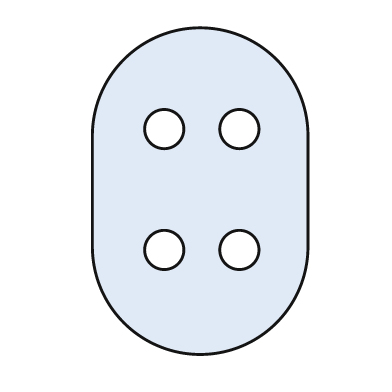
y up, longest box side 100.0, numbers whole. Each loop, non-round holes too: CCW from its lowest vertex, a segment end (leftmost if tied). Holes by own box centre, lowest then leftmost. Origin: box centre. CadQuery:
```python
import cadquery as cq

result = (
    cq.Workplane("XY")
    .moveTo(-33.0, -17.0)
    .threePointArc((0.0, -50.0), (33.0, -17.0))
    .lineTo(33.0, 17.0)
    .threePointArc((0.0, 50.0), (-33.0, 17.0))
    .close()
    .moveTo(-11.0, -18.0)
    .circle(6.0)
    .moveTo(12.0, -18.0)
    .circle(6.0)
    .moveTo(-11.0, 19.0)
    .circle(6.0)
    .moveTo(12.0, 19.0)
    .circle(6.0)
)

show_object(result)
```